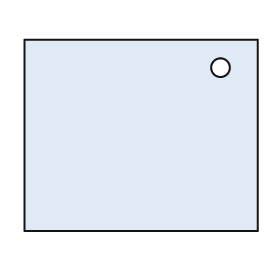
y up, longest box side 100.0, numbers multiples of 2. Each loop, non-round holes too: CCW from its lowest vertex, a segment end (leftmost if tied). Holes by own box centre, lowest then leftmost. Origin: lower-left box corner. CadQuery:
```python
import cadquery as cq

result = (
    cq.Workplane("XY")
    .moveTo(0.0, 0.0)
    .lineTo(100.0, 0.0)
    .lineTo(100.0, 82.0)
    .lineTo(0.0, 82.0)
    .close()
    .moveTo(84.0, 70.0)
    .circle(4.0)
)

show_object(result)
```